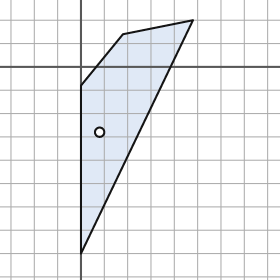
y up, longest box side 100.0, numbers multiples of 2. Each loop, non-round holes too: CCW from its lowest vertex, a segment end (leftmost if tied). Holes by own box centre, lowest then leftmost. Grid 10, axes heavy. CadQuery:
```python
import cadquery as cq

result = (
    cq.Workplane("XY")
    .moveTo(0.0, -80.0)
    .lineTo(48.0, 20.0)
    .lineTo(18.0, 14.0)
    .lineTo(0.0, -8.0)
    .close()
    .moveTo(8.0, -28.0)
    .circle(2.0)
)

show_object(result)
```